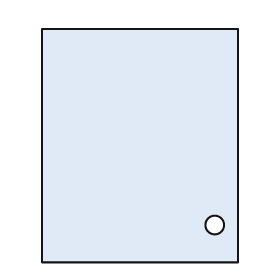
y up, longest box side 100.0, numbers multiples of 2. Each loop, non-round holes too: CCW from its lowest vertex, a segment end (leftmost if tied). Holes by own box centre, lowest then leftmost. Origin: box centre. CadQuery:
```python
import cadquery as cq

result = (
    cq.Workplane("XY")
    .moveTo(-42.0, -50.0)
    .lineTo(42.0, -50.0)
    .lineTo(42.0, 50.0)
    .lineTo(-42.0, 50.0)
    .close()
    .moveTo(32.0, -34.0)
    .circle(4.0)
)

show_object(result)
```